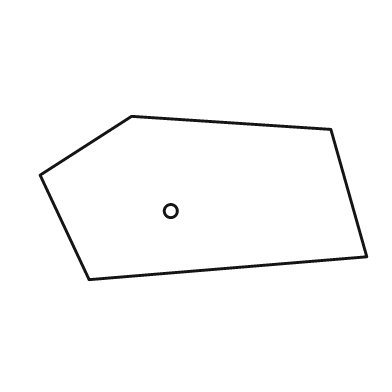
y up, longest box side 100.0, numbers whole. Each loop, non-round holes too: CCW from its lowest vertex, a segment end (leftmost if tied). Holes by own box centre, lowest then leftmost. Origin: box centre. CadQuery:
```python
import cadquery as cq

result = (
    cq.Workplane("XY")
    .moveTo(-35.0, -25.0)
    .lineTo(50.0, -18.0)
    .lineTo(39.0, 21.0)
    .lineTo(-22.0, 25.0)
    .lineTo(-50.0, 7.0)
    .close()
    .moveTo(-10.0, -4.0)
    .circle(2.0)
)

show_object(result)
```